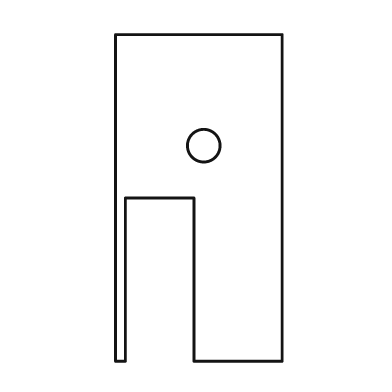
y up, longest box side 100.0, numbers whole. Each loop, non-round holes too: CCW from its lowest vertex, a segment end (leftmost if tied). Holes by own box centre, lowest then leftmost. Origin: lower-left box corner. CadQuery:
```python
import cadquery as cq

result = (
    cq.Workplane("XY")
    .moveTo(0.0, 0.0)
    .lineTo(3.0, 0.0)
    .lineTo(3.0, 50.0)
    .lineTo(24.0, 50.0)
    .lineTo(24.0, 0.0)
    .lineTo(51.0, 0.0)
    .lineTo(51.0, 100.0)
    .lineTo(0.0, 100.0)
    .close()
    .moveTo(27.0, 66.0)
    .circle(5.0)
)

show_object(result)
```